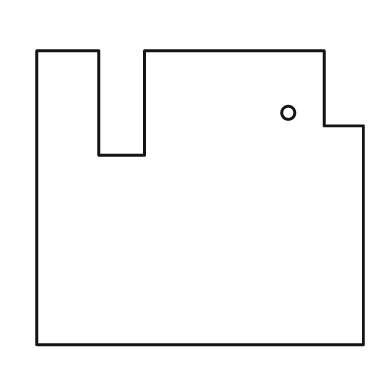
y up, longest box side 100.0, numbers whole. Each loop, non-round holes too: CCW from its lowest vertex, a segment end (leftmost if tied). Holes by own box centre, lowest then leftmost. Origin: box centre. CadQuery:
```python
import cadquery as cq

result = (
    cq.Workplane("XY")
    .moveTo(-50.0, -45.0)
    .lineTo(50.0, -45.0)
    .lineTo(50.0, 22.0)
    .lineTo(38.0, 22.0)
    .lineTo(38.0, 45.0)
    .lineTo(-17.0, 45.0)
    .lineTo(-17.0, 13.0)
    .lineTo(-31.0, 13.0)
    .lineTo(-31.0, 45.0)
    .lineTo(-50.0, 45.0)
    .close()
    .moveTo(27.0, 26.0)
    .circle(2.0)
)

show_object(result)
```